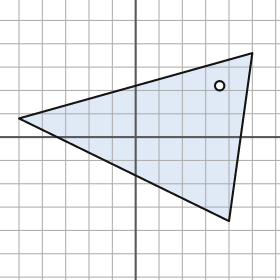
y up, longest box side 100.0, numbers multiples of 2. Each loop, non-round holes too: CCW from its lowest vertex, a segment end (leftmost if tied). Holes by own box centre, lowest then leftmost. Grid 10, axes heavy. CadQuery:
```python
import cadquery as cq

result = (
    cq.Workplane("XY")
    .moveTo(40.0, -36.0)
    .lineTo(50.0, 36.0)
    .lineTo(-50.0, 8.0)
    .close()
    .moveTo(36.0, 22.0)
    .circle(2.0)
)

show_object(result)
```